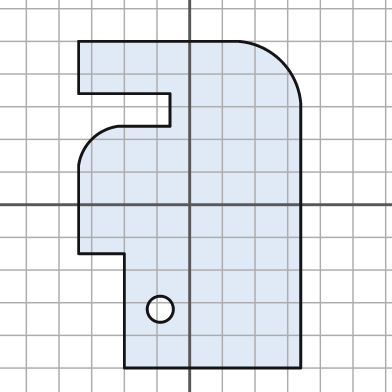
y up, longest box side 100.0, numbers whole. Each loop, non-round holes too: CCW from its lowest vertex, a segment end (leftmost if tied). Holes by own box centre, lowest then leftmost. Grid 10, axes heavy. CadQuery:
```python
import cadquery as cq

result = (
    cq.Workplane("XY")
    .moveTo(-20.0, -50.0)
    .lineTo(34.0, -50.0)
    .lineTo(34.0, 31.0)
    .threePointArc((28.0, 44.0), (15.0, 50.0))
    .lineTo(-34.0, 50.0)
    .lineTo(-34.0, 34.0)
    .lineTo(-6.0, 34.0)
    .lineTo(-6.0, 24.0)
    .lineTo(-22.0, 24.0)
    .threePointArc((-30.0, 20.0), (-34.0, 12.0))
    .lineTo(-34.0, -15.0)
    .lineTo(-20.0, -15.0)
    .close()
    .moveTo(-9.0, -32.0)
    .circle(4.0)
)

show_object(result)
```